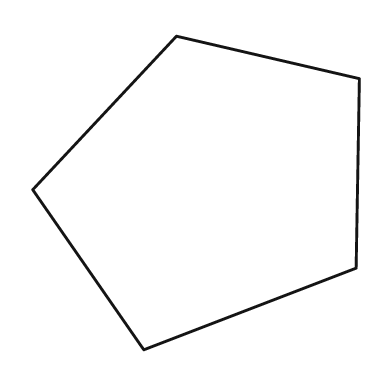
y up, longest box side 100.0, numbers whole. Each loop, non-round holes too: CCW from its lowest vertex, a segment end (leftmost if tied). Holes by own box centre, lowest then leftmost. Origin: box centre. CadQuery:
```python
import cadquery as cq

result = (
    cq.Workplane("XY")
    .moveTo(-16.0, -48.0)
    .lineTo(49.0, -23.0)
    .lineTo(50.0, 35.0)
    .lineTo(-6.0, 48.0)
    .lineTo(-50.0, 1.0)
    .close()
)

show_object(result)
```